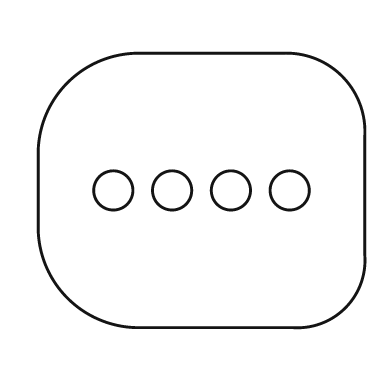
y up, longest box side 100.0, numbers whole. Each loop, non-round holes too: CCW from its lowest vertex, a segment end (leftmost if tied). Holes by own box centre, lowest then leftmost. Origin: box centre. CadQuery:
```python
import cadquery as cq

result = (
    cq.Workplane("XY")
    .moveTo(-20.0, -42.0)
    .lineTo(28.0, -42.0)
    .threePointArc((44.0, -36.0), (50.0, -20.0))
    .lineTo(50.0, 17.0)
    .threePointArc((43.0, 35.0), (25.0, 42.0))
    .lineTo(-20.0, 42.0)
    .threePointArc((-41.0, 33.0), (-50.0, 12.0))
    .lineTo(-50.0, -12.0)
    .threePointArc((-41.0, -33.0), (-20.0, -42.0))
    .close()
    .moveTo(-27.0, 0.0)
    .circle(6.0)
    .moveTo(-9.0, 0.0)
    .circle(6.0)
    .moveTo(9.0, 0.0)
    .circle(6.0)
    .moveTo(27.0, 0.0)
    .circle(6.0)
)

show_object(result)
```